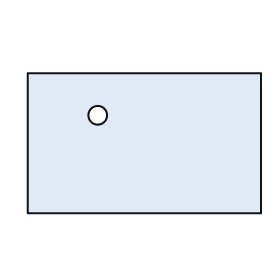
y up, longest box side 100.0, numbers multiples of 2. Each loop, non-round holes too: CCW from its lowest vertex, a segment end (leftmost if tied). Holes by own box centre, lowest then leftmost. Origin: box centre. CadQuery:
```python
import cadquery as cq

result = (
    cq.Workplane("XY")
    .moveTo(-50.0, -30.0)
    .lineTo(50.0, -30.0)
    .lineTo(50.0, 30.0)
    .lineTo(-50.0, 30.0)
    .close()
    .moveTo(-20.0, 12.0)
    .circle(4.0)
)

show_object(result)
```